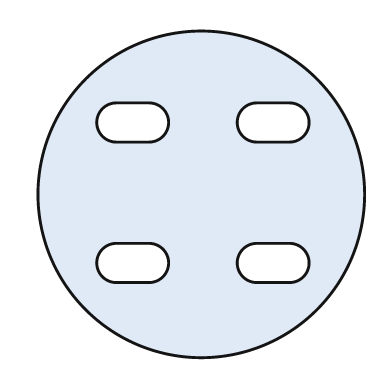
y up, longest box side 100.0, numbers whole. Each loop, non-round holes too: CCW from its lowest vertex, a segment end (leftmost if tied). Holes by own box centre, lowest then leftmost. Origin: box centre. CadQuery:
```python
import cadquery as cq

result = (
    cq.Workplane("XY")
    .moveTo(0.0, 0.0)
    .circle(50.0)
    .moveTo(-26.0, -27.0)
    .lineTo(-16.0, -27.0)
    .threePointArc((-10.0, -21.0), (-16.0, -15.0))
    .lineTo(-26.0, -15.0)
    .threePointArc((-32.0, -21.0), (-26.0, -27.0))
    .close()
    .moveTo(17.0, -27.0)
    .lineTo(27.0, -27.0)
    .threePointArc((33.0, -21.0), (27.0, -15.0))
    .lineTo(17.0, -15.0)
    .threePointArc((11.0, -21.0), (17.0, -27.0))
    .close()
    .moveTo(-26.0, 16.0)
    .lineTo(-16.0, 16.0)
    .threePointArc((-10.0, 22.0), (-16.0, 28.0))
    .lineTo(-26.0, 28.0)
    .threePointArc((-32.0, 22.0), (-26.0, 16.0))
    .close()
    .moveTo(17.0, 16.0)
    .lineTo(27.0, 16.0)
    .threePointArc((33.0, 22.0), (27.0, 28.0))
    .lineTo(17.0, 28.0)
    .threePointArc((11.0, 22.0), (17.0, 16.0))
    .close()
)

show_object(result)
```